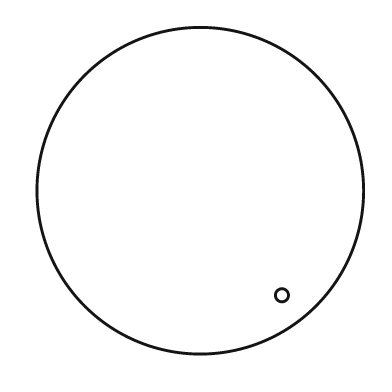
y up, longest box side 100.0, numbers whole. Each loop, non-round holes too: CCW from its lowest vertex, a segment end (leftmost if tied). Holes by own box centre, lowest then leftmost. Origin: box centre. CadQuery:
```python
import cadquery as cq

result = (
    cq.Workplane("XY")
    .moveTo(0.0, 0.0)
    .circle(50.0)
    .moveTo(25.0, -32.0)
    .circle(2.0)
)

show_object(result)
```